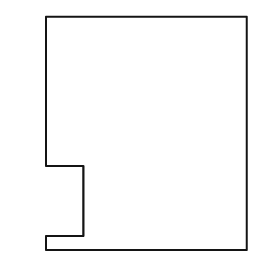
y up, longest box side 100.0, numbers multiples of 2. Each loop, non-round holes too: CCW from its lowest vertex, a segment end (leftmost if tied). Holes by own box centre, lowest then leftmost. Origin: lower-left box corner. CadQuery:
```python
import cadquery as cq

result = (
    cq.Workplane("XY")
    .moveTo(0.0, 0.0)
    .lineTo(86.0, 0.0)
    .lineTo(86.0, 100.0)
    .lineTo(0.0, 100.0)
    .lineTo(0.0, 36.0)
    .lineTo(16.0, 36.0)
    .lineTo(16.0, 6.0)
    .lineTo(0.0, 6.0)
    .close()
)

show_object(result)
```